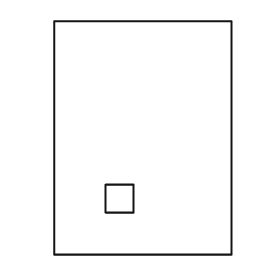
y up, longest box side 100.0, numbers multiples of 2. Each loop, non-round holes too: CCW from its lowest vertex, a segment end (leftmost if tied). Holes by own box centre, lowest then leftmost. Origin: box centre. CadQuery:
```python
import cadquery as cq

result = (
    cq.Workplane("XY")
    .moveTo(-38.0, -50.0)
    .lineTo(38.0, -50.0)
    .lineTo(38.0, 50.0)
    .lineTo(-38.0, 50.0)
    .close()
    .moveTo(-16.0, -32.0)
    .lineTo(-4.0, -32.0)
    .lineTo(-4.0, -20.0)
    .lineTo(-16.0, -20.0)
    .close()
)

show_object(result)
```